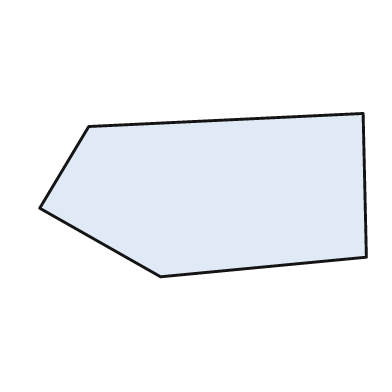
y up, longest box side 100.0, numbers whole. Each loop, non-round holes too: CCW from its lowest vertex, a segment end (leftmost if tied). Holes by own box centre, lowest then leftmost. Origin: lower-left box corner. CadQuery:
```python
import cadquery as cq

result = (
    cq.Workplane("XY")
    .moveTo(37.0, 0.0)
    .lineTo(100.0, 6.0)
    .lineTo(99.0, 50.0)
    .lineTo(15.0, 46.0)
    .lineTo(0.0, 21.0)
    .close()
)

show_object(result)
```